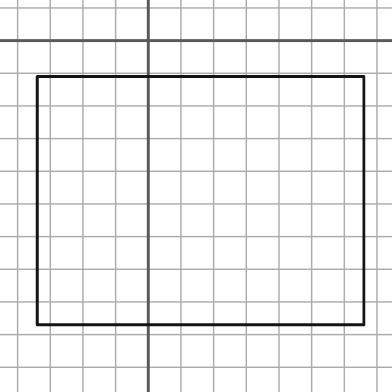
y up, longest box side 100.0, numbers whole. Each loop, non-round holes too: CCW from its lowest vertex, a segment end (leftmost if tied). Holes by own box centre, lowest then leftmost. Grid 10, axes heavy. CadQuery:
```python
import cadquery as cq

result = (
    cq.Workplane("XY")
    .moveTo(-34.0, -87.0)
    .lineTo(66.0, -87.0)
    .lineTo(66.0, -11.0)
    .lineTo(-34.0, -11.0)
    .close()
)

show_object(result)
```